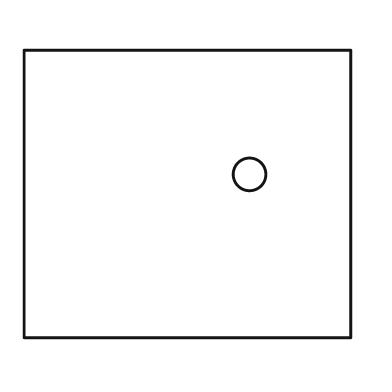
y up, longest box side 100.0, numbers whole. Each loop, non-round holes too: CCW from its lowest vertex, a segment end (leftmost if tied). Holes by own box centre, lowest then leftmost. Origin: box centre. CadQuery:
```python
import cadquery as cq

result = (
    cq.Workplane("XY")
    .moveTo(-50.0, -44.0)
    .lineTo(50.0, -44.0)
    .lineTo(50.0, 44.0)
    .lineTo(-50.0, 44.0)
    .close()
    .moveTo(19.0, 6.0)
    .circle(5.0)
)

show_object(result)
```